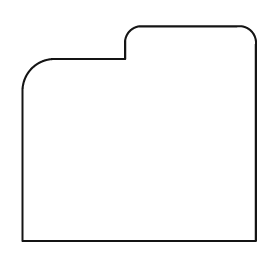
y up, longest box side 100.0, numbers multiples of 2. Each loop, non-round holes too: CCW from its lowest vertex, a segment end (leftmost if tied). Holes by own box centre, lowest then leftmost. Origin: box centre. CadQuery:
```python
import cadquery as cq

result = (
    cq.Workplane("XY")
    .moveTo(-50.0, -46.0)
    .lineTo(50.0, -46.0)
    .lineTo(50.0, 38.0)
    .threePointArc((48.0, 44.0), (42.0, 46.0))
    .lineTo(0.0, 46.0)
    .threePointArc((-4.0, 44.0), (-6.0, 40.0))
    .lineTo(-6.0, 32.0)
    .lineTo(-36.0, 32.0)
    .threePointArc((-46.0, 28.0), (-50.0, 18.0))
    .close()
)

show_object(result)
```